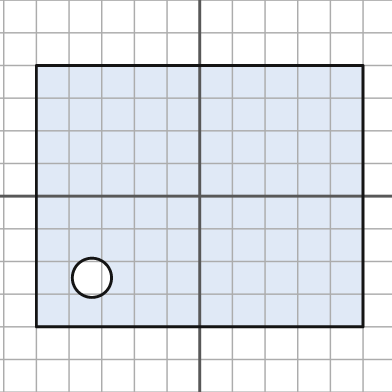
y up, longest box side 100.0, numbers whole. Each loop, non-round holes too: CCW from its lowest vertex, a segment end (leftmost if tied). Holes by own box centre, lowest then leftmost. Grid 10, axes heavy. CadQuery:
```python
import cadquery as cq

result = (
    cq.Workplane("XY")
    .moveTo(-50.0, -40.0)
    .lineTo(50.0, -40.0)
    .lineTo(50.0, 40.0)
    .lineTo(-50.0, 40.0)
    .close()
    .moveTo(-33.0, -25.0)
    .circle(6.0)
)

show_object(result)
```